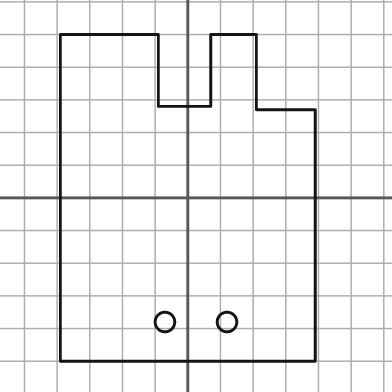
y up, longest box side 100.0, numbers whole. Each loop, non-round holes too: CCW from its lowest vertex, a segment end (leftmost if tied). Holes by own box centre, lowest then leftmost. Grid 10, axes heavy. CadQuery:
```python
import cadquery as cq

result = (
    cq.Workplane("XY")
    .moveTo(-39.0, -50.0)
    .lineTo(39.0, -50.0)
    .lineTo(39.0, 27.0)
    .lineTo(21.0, 27.0)
    .lineTo(21.0, 50.0)
    .lineTo(7.0, 50.0)
    .lineTo(7.0, 28.0)
    .lineTo(-9.0, 28.0)
    .lineTo(-9.0, 50.0)
    .lineTo(-39.0, 50.0)
    .close()
    .moveTo(-7.0, -38.0)
    .circle(3.0)
    .moveTo(12.0, -38.0)
    .circle(3.0)
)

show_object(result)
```